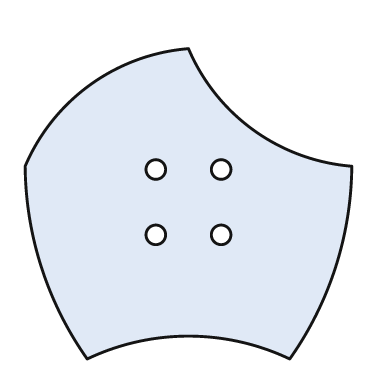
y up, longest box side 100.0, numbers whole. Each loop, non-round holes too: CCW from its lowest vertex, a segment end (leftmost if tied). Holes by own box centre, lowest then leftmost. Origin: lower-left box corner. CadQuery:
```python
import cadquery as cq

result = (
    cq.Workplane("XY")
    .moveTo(19.0, 0.0)
    .threePointArc((50.0, 7.0), (81.0, 0.0))
    .threePointArc((95.0, 28.0), (100.0, 59.0))
    .threePointArc((70.0, 70.0), (50.0, 95.0))
    .threePointArc((20.0, 84.0), (0.0, 59.0))
    .threePointArc((5.0, 28.0), (19.0, 0.0))
    .close()
    .moveTo(40.0, 38.0)
    .circle(3.0)
    .moveTo(60.0, 38.0)
    .circle(3.0)
    .moveTo(40.0, 58.0)
    .circle(3.0)
    .moveTo(60.0, 58.0)
    .circle(3.0)
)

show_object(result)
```